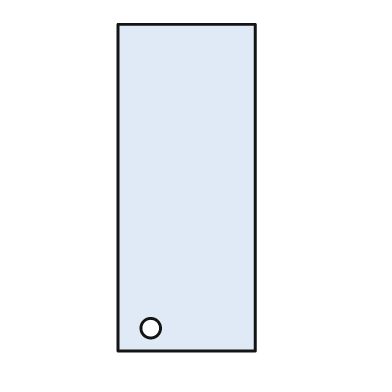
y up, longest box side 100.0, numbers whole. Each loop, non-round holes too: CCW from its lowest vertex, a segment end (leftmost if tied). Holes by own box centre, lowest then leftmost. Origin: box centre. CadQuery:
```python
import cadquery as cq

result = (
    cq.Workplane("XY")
    .moveTo(-21.0, -50.0)
    .lineTo(21.0, -50.0)
    .lineTo(21.0, 50.0)
    .lineTo(-21.0, 50.0)
    .close()
    .moveTo(-11.0, -43.0)
    .circle(3.0)
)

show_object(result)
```